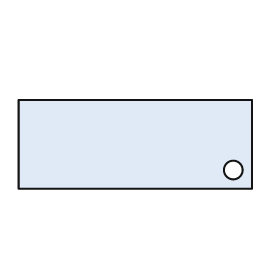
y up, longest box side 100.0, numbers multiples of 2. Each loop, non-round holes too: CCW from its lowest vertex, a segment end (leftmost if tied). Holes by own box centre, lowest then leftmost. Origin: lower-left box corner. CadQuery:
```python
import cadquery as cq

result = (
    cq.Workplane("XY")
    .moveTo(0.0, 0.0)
    .lineTo(100.0, 0.0)
    .lineTo(100.0, 38.0)
    .lineTo(0.0, 38.0)
    .close()
    .moveTo(92.0, 8.0)
    .circle(4.0)
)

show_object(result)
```